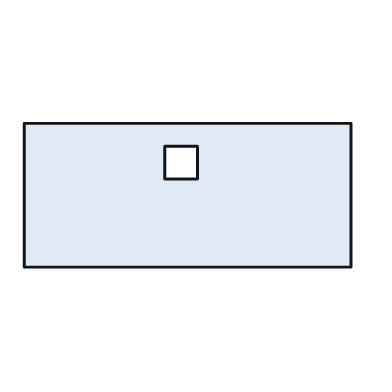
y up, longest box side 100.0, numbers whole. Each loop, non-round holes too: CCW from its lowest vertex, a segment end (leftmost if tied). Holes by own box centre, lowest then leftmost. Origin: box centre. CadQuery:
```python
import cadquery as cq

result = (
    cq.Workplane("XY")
    .moveTo(-50.0, -22.0)
    .lineTo(50.0, -22.0)
    .lineTo(50.0, 22.0)
    .lineTo(-50.0, 22.0)
    .close()
    .moveTo(-7.0, 5.0)
    .lineTo(3.0, 5.0)
    .lineTo(3.0, 15.0)
    .lineTo(-7.0, 15.0)
    .close()
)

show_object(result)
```